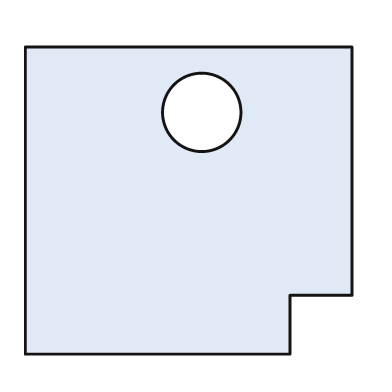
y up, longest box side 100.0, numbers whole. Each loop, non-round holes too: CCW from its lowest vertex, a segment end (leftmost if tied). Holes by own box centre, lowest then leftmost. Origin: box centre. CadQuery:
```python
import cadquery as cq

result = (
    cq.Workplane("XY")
    .moveTo(-50.0, -47.0)
    .lineTo(31.0, -47.0)
    .lineTo(31.0, -29.0)
    .lineTo(50.0, -29.0)
    .lineTo(50.0, 47.0)
    .lineTo(-50.0, 47.0)
    .close()
    .moveTo(4.0, 27.0)
    .circle(12.0)
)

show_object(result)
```